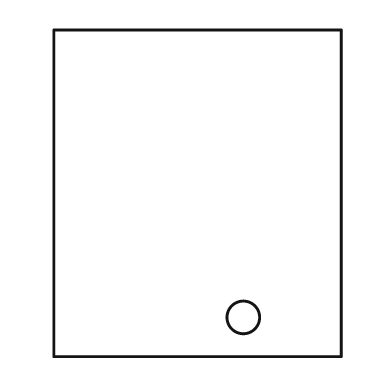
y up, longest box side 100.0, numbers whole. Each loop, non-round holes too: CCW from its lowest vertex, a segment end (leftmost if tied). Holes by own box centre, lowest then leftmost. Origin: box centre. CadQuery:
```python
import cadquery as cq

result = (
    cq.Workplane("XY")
    .moveTo(-44.0, -50.0)
    .lineTo(44.0, -50.0)
    .lineTo(44.0, 50.0)
    .lineTo(-44.0, 50.0)
    .close()
    .moveTo(14.0, -38.0)
    .circle(5.0)
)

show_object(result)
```